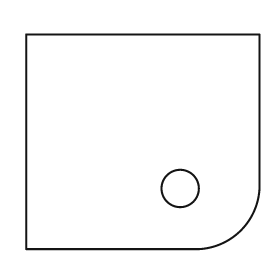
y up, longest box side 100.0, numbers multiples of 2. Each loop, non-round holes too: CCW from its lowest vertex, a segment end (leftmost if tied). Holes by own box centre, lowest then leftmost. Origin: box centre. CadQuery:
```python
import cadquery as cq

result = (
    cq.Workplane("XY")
    .moveTo(-50.0, -46.0)
    .lineTo(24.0, -46.0)
    .threePointArc((42.0, -38.0), (50.0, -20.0))
    .lineTo(50.0, 46.0)
    .lineTo(-50.0, 46.0)
    .close()
    .moveTo(16.0, -20.0)
    .circle(8.0)
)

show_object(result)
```